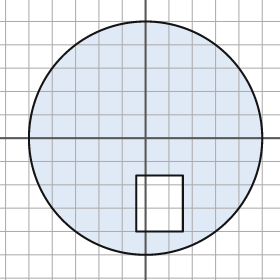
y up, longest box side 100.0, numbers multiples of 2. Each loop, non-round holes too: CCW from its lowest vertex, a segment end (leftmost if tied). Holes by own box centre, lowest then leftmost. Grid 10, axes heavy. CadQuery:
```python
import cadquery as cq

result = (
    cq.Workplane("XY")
    .moveTo(0.0, 0.0)
    .circle(50.0)
    .moveTo(-4.0, -40.0)
    .lineTo(16.0, -40.0)
    .lineTo(16.0, -16.0)
    .lineTo(-4.0, -16.0)
    .close()
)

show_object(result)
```